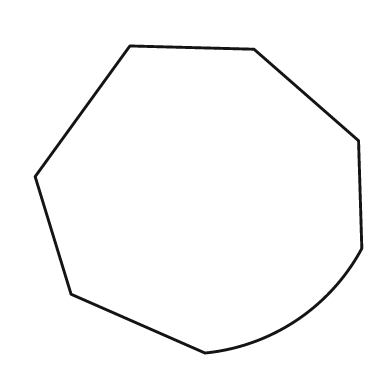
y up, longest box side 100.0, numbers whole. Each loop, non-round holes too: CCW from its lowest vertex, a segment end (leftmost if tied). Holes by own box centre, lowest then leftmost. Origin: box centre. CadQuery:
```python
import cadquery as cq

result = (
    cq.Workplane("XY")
    .moveTo(2.0, -47.0)
    .threePointArc((30.0, -37.0), (50.0, -15.0))
    .lineTo(49.0, 18.0)
    .lineTo(17.0, 46.0)
    .lineTo(-21.0, 47.0)
    .lineTo(-50.0, 7.0)
    .lineTo(-39.0, -29.0)
    .close()
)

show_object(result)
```